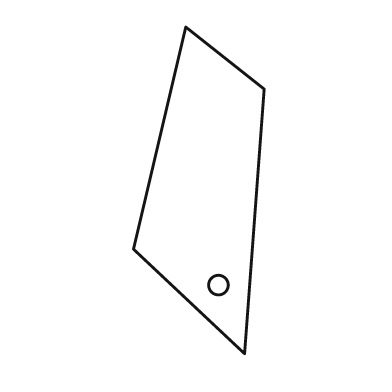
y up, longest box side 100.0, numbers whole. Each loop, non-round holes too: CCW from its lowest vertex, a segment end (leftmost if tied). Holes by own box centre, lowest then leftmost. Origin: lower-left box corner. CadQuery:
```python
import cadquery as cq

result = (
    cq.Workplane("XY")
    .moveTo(34.0, 0.0)
    .lineTo(40.0, 81.0)
    .lineTo(16.0, 100.0)
    .lineTo(0.0, 32.0)
    .close()
    .moveTo(26.0, 21.0)
    .circle(3.0)
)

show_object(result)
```